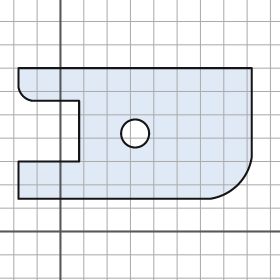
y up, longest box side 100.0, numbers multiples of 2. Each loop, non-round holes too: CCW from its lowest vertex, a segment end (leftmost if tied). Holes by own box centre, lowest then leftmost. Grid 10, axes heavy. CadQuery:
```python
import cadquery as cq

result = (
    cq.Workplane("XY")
    .moveTo(-18.0, 14.0)
    .lineTo(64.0, 14.0)
    .threePointArc((76.0, 20.0), (82.0, 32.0))
    .lineTo(82.0, 70.0)
    .lineTo(-18.0, 70.0)
    .lineTo(-18.0, 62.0)
    .threePointArc((-16.0, 58.0), (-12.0, 56.0))
    .lineTo(8.0, 56.0)
    .lineTo(8.0, 30.0)
    .lineTo(-18.0, 30.0)
    .close()
    .moveTo(32.0, 42.0)
    .circle(6.0)
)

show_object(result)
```